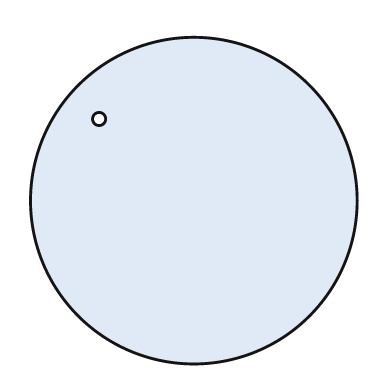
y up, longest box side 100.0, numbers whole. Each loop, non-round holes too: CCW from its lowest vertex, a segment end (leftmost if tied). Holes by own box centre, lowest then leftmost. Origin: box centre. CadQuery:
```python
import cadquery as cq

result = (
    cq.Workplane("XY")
    .moveTo(0.0, 0.0)
    .circle(50.0)
    .moveTo(-29.0, 25.0)
    .circle(2.0)
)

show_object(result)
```